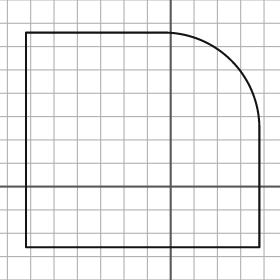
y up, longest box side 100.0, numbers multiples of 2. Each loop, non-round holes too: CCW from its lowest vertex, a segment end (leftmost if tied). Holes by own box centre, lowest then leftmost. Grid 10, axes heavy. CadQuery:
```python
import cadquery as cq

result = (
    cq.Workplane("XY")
    .moveTo(-62.0, -26.0)
    .lineTo(38.0, -26.0)
    .lineTo(38.0, 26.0)
    .threePointArc((26.0, 54.0), (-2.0, 66.0))
    .lineTo(-62.0, 66.0)
    .close()
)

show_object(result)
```